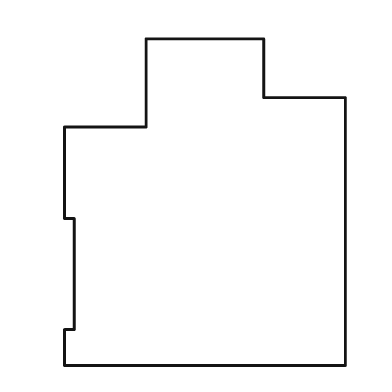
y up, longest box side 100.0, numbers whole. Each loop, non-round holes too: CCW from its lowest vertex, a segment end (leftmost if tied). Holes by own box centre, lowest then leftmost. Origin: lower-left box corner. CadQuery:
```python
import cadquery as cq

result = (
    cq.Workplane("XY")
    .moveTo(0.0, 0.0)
    .lineTo(86.0, 0.0)
    .lineTo(86.0, 82.0)
    .lineTo(61.0, 82.0)
    .lineTo(61.0, 100.0)
    .lineTo(25.0, 100.0)
    .lineTo(25.0, 73.0)
    .lineTo(0.0, 73.0)
    .lineTo(0.0, 45.0)
    .lineTo(3.0, 45.0)
    .lineTo(3.0, 11.0)
    .lineTo(0.0, 11.0)
    .close()
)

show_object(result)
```